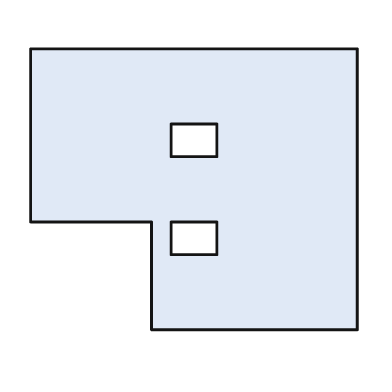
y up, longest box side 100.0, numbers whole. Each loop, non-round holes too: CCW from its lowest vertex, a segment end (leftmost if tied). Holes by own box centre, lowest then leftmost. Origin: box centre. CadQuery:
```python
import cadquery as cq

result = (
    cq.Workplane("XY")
    .moveTo(-13.0, -43.0)
    .lineTo(50.0, -43.0)
    .lineTo(50.0, 43.0)
    .lineTo(-50.0, 43.0)
    .lineTo(-50.0, -10.0)
    .lineTo(-13.0, -10.0)
    .close()
    .moveTo(-7.0, -20.0)
    .lineTo(7.0, -20.0)
    .lineTo(7.0, -10.0)
    .lineTo(-7.0, -10.0)
    .close()
    .moveTo(-7.0, 10.0)
    .lineTo(7.0, 10.0)
    .lineTo(7.0, 20.0)
    .lineTo(-7.0, 20.0)
    .close()
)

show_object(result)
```